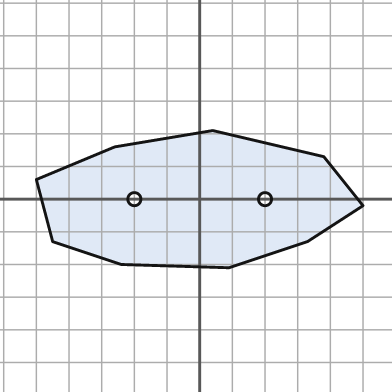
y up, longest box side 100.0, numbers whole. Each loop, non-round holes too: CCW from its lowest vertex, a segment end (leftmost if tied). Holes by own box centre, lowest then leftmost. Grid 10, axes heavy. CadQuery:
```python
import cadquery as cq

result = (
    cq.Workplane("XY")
    .moveTo(9.0, -21.0)
    .lineTo(33.0, -13.0)
    .lineTo(50.0, -2.0)
    .lineTo(38.0, 13.0)
    .lineTo(4.0, 21.0)
    .lineTo(-26.0, 16.0)
    .lineTo(-50.0, 6.0)
    .lineTo(-45.0, -13.0)
    .lineTo(-24.0, -20.0)
    .close()
    .moveTo(-20.0, 0.0)
    .circle(2.0)
    .moveTo(20.0, 0.0)
    .circle(2.0)
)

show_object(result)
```